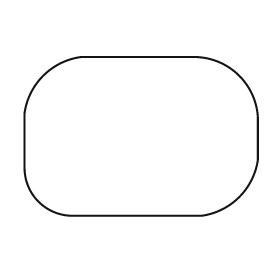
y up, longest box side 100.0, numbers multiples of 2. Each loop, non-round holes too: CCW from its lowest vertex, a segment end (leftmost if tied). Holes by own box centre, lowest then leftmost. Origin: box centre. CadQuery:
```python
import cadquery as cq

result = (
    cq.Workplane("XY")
    .moveTo(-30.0, -34.0)
    .lineTo(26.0, -34.0)
    .threePointArc((42.0, -26.0), (50.0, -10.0))
    .lineTo(50.0, 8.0)
    .threePointArc((42.0, 26.0), (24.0, 34.0))
    .lineTo(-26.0, 34.0)
    .threePointArc((-42.0, 26.0), (-50.0, 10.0))
    .lineTo(-50.0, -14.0)
    .threePointArc((-44.0, -28.0), (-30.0, -34.0))
    .close()
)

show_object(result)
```